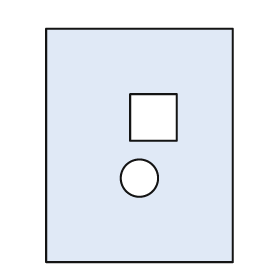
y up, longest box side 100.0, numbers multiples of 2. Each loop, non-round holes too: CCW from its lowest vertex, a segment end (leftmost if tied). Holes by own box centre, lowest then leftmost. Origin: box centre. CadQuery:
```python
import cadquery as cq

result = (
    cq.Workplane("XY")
    .moveTo(-40.0, -50.0)
    .lineTo(40.0, -50.0)
    .lineTo(40.0, 50.0)
    .lineTo(-40.0, 50.0)
    .close()
    .moveTo(0.0, -14.0)
    .circle(8.0)
    .moveTo(-4.0, 2.0)
    .lineTo(16.0, 2.0)
    .lineTo(16.0, 22.0)
    .lineTo(-4.0, 22.0)
    .close()
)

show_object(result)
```